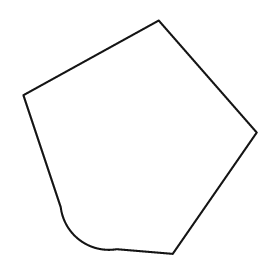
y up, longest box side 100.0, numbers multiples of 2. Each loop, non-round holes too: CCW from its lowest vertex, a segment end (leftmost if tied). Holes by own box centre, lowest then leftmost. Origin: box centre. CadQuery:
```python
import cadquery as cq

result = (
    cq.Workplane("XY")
    .moveTo(14.0, -50.0)
    .lineTo(50.0, 2.0)
    .lineTo(8.0, 50.0)
    .lineTo(-50.0, 18.0)
    .lineTo(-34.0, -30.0)
    .threePointArc((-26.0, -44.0), (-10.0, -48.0))
    .close()
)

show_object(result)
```